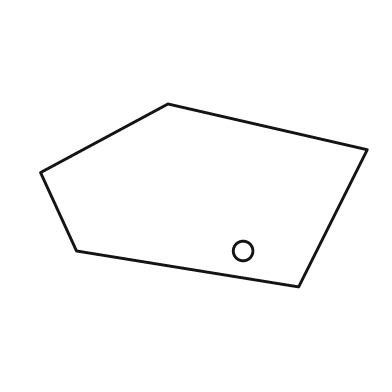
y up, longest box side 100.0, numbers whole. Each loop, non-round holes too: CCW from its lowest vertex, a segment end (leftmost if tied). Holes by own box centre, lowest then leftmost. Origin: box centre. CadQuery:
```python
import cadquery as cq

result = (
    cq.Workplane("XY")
    .moveTo(29.0, -28.0)
    .lineTo(50.0, 14.0)
    .lineTo(-11.0, 28.0)
    .lineTo(-50.0, 7.0)
    .lineTo(-39.0, -17.0)
    .close()
    .moveTo(12.0, -17.0)
    .circle(3.0)
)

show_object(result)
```